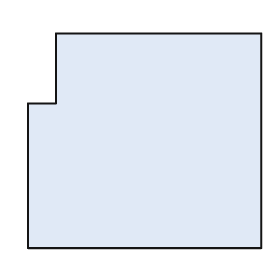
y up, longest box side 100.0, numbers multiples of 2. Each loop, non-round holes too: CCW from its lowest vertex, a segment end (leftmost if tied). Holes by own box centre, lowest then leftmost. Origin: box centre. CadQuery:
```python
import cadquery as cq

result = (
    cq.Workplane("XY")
    .moveTo(-50.0, -46.0)
    .lineTo(50.0, -46.0)
    .lineTo(50.0, 46.0)
    .lineTo(-38.0, 46.0)
    .lineTo(-38.0, 16.0)
    .lineTo(-50.0, 16.0)
    .close()
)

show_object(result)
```